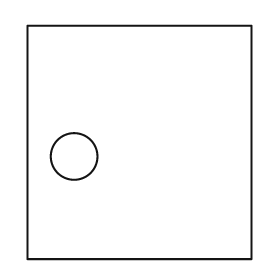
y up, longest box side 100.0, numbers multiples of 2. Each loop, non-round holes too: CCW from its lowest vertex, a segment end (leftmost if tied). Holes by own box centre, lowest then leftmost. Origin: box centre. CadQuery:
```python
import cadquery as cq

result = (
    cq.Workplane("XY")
    .moveTo(-48.0, -50.0)
    .lineTo(48.0, -50.0)
    .lineTo(48.0, 50.0)
    .lineTo(-48.0, 50.0)
    .close()
    .moveTo(-28.0, -6.0)
    .circle(10.0)
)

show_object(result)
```